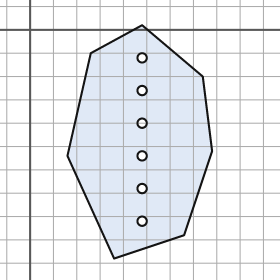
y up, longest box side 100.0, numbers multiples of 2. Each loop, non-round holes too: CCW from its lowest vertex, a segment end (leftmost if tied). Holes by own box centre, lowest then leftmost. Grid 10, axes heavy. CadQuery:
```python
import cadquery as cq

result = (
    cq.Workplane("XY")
    .moveTo(36.0, -98.0)
    .lineTo(66.0, -88.0)
    .lineTo(78.0, -52.0)
    .lineTo(74.0, -20.0)
    .lineTo(48.0, 2.0)
    .lineTo(26.0, -10.0)
    .lineTo(16.0, -54.0)
    .close()
    .moveTo(48.0, -82.0)
    .circle(2.0)
    .moveTo(48.0, -68.0)
    .circle(2.0)
    .moveTo(48.0, -54.0)
    .circle(2.0)
    .moveTo(48.0, -40.0)
    .circle(2.0)
    .moveTo(48.0, -26.0)
    .circle(2.0)
    .moveTo(48.0, -12.0)
    .circle(2.0)
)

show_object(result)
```